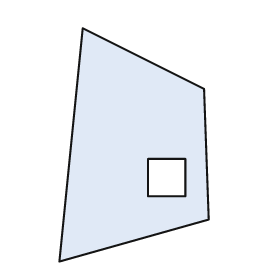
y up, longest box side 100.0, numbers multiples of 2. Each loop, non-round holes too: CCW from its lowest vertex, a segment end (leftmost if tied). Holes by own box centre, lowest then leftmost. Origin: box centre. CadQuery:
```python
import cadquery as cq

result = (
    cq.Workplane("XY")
    .moveTo(-32.0, -50.0)
    .lineTo(32.0, -32.0)
    .lineTo(30.0, 24.0)
    .lineTo(-22.0, 50.0)
    .close()
    .moveTo(6.0, -22.0)
    .lineTo(22.0, -22.0)
    .lineTo(22.0, -6.0)
    .lineTo(6.0, -6.0)
    .close()
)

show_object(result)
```